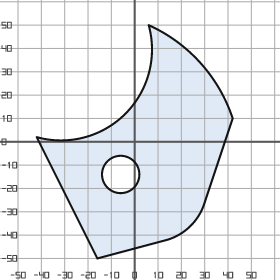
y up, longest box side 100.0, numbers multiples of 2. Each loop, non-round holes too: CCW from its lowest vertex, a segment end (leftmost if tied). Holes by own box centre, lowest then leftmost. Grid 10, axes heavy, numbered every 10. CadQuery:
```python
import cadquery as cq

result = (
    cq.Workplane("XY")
    .moveTo(-16.0, -50.0)
    .lineTo(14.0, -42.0)
    .threePointArc((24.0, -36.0), (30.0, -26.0))
    .lineTo(42.0, 10.0)
    .threePointArc((28.0, 34.0), (6.0, 50.0))
    .threePointArc((-4.0, 12.0), (-42.0, 2.0))
    .close()
    .moveTo(-6.0, -14.0)
    .circle(8.0)
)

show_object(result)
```